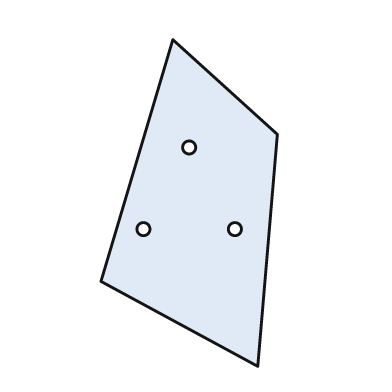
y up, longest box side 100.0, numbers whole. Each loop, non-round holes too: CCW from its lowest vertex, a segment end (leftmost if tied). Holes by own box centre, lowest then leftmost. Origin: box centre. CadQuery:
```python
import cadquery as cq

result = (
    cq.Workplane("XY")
    .moveTo(21.0, -50.0)
    .lineTo(27.0, 21.0)
    .lineTo(-5.0, 50.0)
    .lineTo(-27.0, -24.0)
    .close()
    .moveTo(-14.0, -8.0)
    .circle(2.0)
    .moveTo(14.0, -8.0)
    .circle(2.0)
    .moveTo(0.0, 17.0)
    .circle(2.0)
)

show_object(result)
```